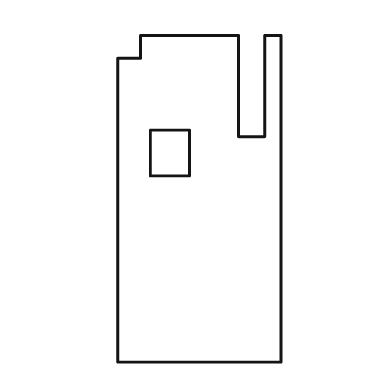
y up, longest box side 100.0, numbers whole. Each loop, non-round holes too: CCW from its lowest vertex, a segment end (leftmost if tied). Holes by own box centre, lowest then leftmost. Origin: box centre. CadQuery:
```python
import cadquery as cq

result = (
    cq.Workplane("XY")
    .moveTo(-25.0, -50.0)
    .lineTo(25.0, -50.0)
    .lineTo(25.0, 50.0)
    .lineTo(20.0, 50.0)
    .lineTo(20.0, 19.0)
    .lineTo(12.0, 19.0)
    .lineTo(12.0, 50.0)
    .lineTo(-18.0, 50.0)
    .lineTo(-18.0, 43.0)
    .lineTo(-25.0, 43.0)
    .close()
    .moveTo(-15.0, 7.0)
    .lineTo(-3.0, 7.0)
    .lineTo(-3.0, 21.0)
    .lineTo(-15.0, 21.0)
    .close()
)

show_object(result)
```